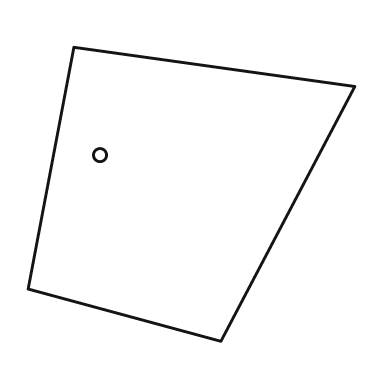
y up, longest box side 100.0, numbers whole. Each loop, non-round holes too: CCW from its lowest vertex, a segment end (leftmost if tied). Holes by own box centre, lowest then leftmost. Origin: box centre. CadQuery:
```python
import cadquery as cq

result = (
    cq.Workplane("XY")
    .moveTo(9.0, -45.0)
    .lineTo(50.0, 33.0)
    .lineTo(-36.0, 45.0)
    .lineTo(-50.0, -29.0)
    .close()
    .moveTo(-28.0, 12.0)
    .circle(2.0)
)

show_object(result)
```